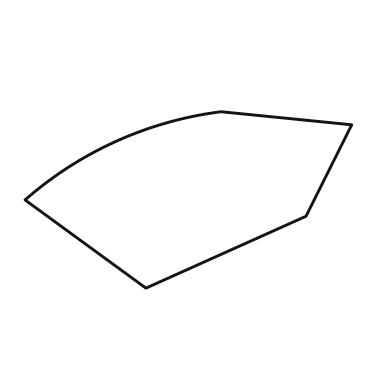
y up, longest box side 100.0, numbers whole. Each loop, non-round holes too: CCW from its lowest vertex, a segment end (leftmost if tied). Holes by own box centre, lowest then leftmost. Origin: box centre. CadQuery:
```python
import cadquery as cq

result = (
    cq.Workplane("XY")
    .moveTo(-13.0, -27.0)
    .lineTo(36.0, -5.0)
    .lineTo(50.0, 23.0)
    .lineTo(10.0, 27.0)
    .threePointArc((-22.0, 18.0), (-50.0, 0.0))
    .close()
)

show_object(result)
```